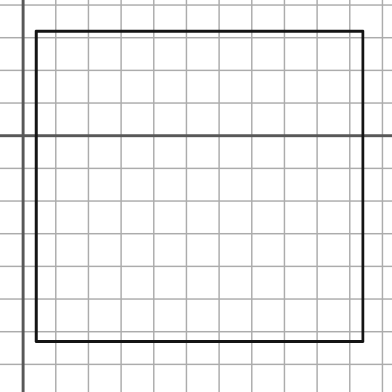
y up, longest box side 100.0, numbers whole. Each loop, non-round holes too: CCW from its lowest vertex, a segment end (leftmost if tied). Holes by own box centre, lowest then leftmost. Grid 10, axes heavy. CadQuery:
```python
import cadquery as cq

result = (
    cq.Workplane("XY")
    .moveTo(4.0, -63.0)
    .lineTo(104.0, -63.0)
    .lineTo(104.0, 32.0)
    .lineTo(4.0, 32.0)
    .close()
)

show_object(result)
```